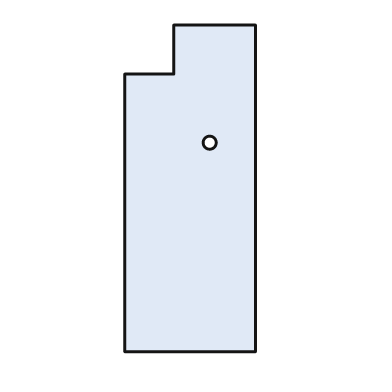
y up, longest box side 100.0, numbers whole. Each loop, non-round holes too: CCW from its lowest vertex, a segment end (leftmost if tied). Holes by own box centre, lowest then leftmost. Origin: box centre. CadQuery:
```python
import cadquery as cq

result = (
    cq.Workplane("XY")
    .moveTo(-20.0, -50.0)
    .lineTo(20.0, -50.0)
    .lineTo(20.0, 50.0)
    .lineTo(-5.0, 50.0)
    .lineTo(-5.0, 35.0)
    .lineTo(-20.0, 35.0)
    .close()
    .moveTo(6.0, 14.0)
    .circle(2.0)
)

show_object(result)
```